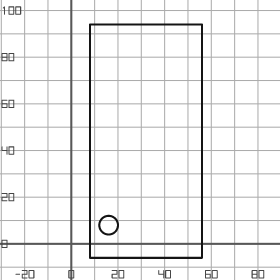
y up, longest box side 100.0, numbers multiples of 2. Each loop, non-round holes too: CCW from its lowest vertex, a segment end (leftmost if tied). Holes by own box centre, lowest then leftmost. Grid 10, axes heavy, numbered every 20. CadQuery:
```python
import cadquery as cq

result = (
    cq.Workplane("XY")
    .moveTo(8.0, -6.0)
    .lineTo(56.0, -6.0)
    .lineTo(56.0, 94.0)
    .lineTo(8.0, 94.0)
    .close()
    .moveTo(16.0, 8.0)
    .circle(4.0)
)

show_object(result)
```